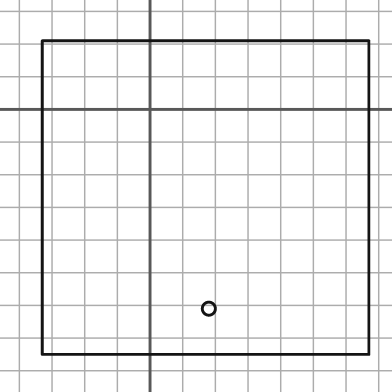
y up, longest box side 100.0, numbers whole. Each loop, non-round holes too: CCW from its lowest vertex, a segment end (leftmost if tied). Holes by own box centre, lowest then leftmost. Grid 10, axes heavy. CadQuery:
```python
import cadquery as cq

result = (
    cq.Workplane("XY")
    .moveTo(-33.0, -75.0)
    .lineTo(67.0, -75.0)
    .lineTo(67.0, 21.0)
    .lineTo(-33.0, 21.0)
    .close()
    .moveTo(18.0, -61.0)
    .circle(2.0)
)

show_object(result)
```